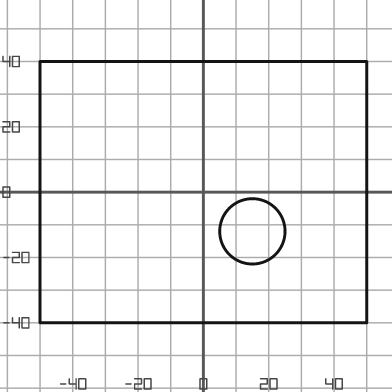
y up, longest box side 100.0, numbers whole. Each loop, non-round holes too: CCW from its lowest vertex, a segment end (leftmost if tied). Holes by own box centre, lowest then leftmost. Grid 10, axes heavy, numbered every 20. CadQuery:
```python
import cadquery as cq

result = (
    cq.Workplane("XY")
    .moveTo(-50.0, -40.0)
    .lineTo(50.0, -40.0)
    .lineTo(50.0, 40.0)
    .lineTo(-50.0, 40.0)
    .close()
    .moveTo(15.0, -12.0)
    .circle(10.0)
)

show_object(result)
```